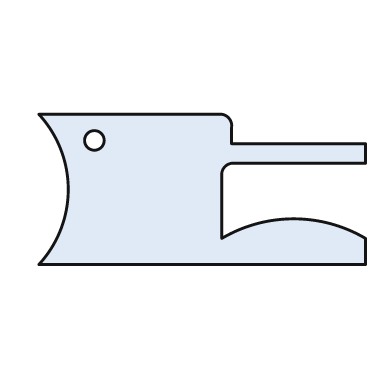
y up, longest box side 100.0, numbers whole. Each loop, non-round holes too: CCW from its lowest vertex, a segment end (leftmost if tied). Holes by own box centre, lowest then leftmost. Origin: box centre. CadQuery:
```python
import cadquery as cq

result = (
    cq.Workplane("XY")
    .moveTo(-50.0, -23.0)
    .lineTo(50.0, -23.0)
    .lineTo(50.0, -15.0)
    .threePointArc((28.0, -9.0), (6.0, -15.0))
    .lineTo(6.0, 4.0)
    .threePointArc((7.0, 7.0), (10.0, 8.0))
    .lineTo(50.0, 8.0)
    .lineTo(50.0, 14.0)
    .lineTo(9.0, 14.0)
    .lineTo(9.0, 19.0)
    .threePointArc((8.0, 22.0), (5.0, 23.0))
    .lineTo(-50.0, 23.0)
    .threePointArc((-41.0, 0.0), (-50.0, -23.0))
    .close()
    .moveTo(-33.0, 15.0)
    .circle(3.0)
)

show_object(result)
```